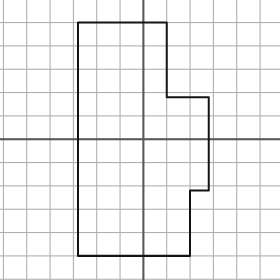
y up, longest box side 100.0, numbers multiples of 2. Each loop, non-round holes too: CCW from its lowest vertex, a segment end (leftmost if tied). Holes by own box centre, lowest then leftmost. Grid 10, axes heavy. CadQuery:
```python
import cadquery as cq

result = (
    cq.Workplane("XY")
    .moveTo(-28.0, -50.0)
    .lineTo(20.0, -50.0)
    .lineTo(20.0, -22.0)
    .lineTo(28.0, -22.0)
    .lineTo(28.0, 18.0)
    .lineTo(10.0, 18.0)
    .lineTo(10.0, 50.0)
    .lineTo(-28.0, 50.0)
    .close()
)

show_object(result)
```